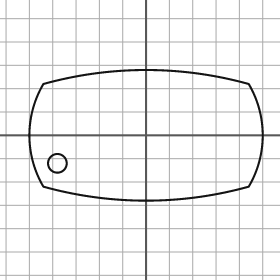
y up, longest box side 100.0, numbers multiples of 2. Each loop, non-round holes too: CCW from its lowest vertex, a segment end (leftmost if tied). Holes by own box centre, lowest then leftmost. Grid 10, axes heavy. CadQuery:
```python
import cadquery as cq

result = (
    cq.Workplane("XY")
    .moveTo(-44.0, -22.0)
    .threePointArc((0.0, -28.0), (44.0, -22.0))
    .threePointArc((50.0, 0.0), (44.0, 22.0))
    .threePointArc((0.0, 28.0), (-44.0, 22.0))
    .threePointArc((-50.0, 0.0), (-44.0, -22.0))
    .close()
    .moveTo(-38.0, -12.0)
    .circle(4.0)
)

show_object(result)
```